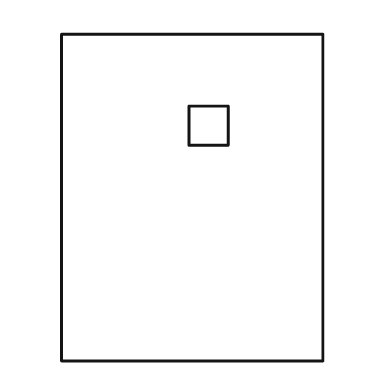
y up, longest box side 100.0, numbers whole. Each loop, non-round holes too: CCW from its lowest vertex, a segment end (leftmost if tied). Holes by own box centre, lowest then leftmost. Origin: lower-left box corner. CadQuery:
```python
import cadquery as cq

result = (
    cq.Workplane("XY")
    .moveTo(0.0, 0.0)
    .lineTo(80.0, 0.0)
    .lineTo(80.0, 100.0)
    .lineTo(0.0, 100.0)
    .close()
    .moveTo(39.0, 66.0)
    .lineTo(51.0, 66.0)
    .lineTo(51.0, 78.0)
    .lineTo(39.0, 78.0)
    .close()
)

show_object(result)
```